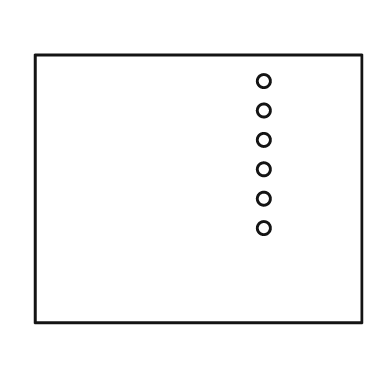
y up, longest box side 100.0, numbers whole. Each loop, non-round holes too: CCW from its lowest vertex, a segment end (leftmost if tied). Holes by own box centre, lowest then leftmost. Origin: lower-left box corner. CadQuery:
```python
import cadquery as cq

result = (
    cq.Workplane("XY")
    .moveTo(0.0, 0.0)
    .lineTo(100.0, 0.0)
    .lineTo(100.0, 82.0)
    .lineTo(0.0, 82.0)
    .close()
    .moveTo(70.0, 29.0)
    .circle(2.0)
    .moveTo(70.0, 38.0)
    .circle(2.0)
    .moveTo(70.0, 47.0)
    .circle(2.0)
    .moveTo(70.0, 56.0)
    .circle(2.0)
    .moveTo(70.0, 65.0)
    .circle(2.0)
    .moveTo(70.0, 74.0)
    .circle(2.0)
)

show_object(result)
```